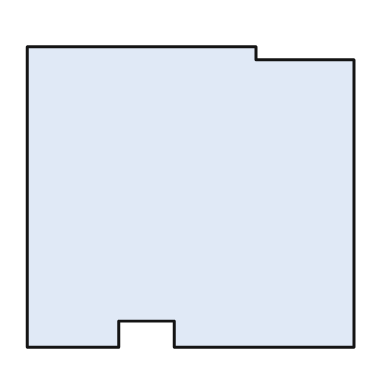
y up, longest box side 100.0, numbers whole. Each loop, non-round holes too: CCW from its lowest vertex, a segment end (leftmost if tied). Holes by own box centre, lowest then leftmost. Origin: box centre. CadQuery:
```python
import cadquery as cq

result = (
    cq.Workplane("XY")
    .moveTo(-50.0, -46.0)
    .lineTo(-22.0, -46.0)
    .lineTo(-22.0, -38.0)
    .lineTo(-5.0, -38.0)
    .lineTo(-5.0, -46.0)
    .lineTo(50.0, -46.0)
    .lineTo(50.0, 42.0)
    .lineTo(20.0, 42.0)
    .lineTo(20.0, 46.0)
    .lineTo(-50.0, 46.0)
    .close()
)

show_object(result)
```